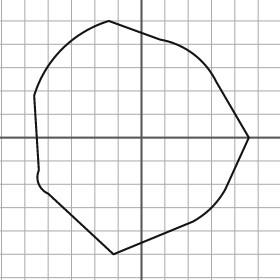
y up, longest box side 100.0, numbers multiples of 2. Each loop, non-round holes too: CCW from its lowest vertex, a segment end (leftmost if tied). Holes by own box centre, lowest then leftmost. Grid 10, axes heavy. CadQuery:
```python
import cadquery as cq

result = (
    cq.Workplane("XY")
    .moveTo(-12.0, -50.0)
    .lineTo(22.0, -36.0)
    .threePointArc((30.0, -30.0), (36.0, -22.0))
    .lineTo(46.0, 0.0)
    .lineTo(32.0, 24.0)
    .threePointArc((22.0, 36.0), (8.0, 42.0))
    .lineTo(-14.0, 50.0)
    .threePointArc((-34.0, 38.0), (-46.0, 18.0))
    .lineTo(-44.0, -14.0)
    .threePointArc((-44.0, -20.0), (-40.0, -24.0))
    .close()
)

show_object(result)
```